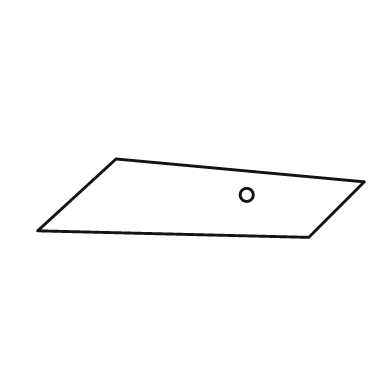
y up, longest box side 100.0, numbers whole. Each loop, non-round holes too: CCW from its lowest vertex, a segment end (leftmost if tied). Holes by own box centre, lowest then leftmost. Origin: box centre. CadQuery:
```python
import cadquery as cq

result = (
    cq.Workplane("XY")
    .moveTo(33.0, -12.0)
    .lineTo(50.0, 5.0)
    .lineTo(-26.0, 12.0)
    .lineTo(-50.0, -10.0)
    .close()
    .moveTo(14.0, 1.0)
    .circle(2.0)
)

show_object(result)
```